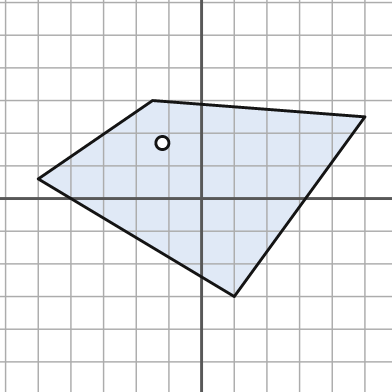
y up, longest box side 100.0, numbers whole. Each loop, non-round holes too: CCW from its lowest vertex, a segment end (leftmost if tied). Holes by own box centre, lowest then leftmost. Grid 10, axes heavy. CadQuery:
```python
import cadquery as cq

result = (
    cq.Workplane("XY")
    .moveTo(10.0, -30.0)
    .lineTo(50.0, 25.0)
    .lineTo(-15.0, 30.0)
    .lineTo(-50.0, 6.0)
    .close()
    .moveTo(-12.0, 17.0)
    .circle(2.0)
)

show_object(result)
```